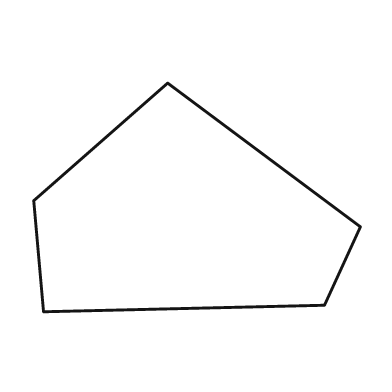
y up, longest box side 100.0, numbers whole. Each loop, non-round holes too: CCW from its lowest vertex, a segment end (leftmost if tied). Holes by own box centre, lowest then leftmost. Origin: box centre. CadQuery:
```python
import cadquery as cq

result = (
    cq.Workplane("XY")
    .moveTo(-47.0, -35.0)
    .lineTo(39.0, -33.0)
    .lineTo(50.0, -9.0)
    .lineTo(-9.0, 35.0)
    .lineTo(-50.0, -1.0)
    .close()
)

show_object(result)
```